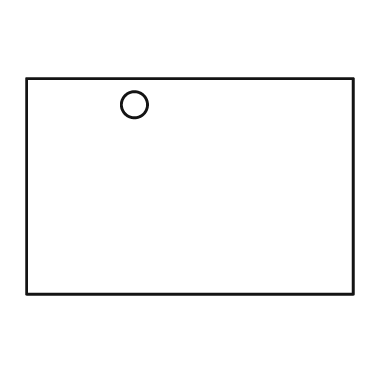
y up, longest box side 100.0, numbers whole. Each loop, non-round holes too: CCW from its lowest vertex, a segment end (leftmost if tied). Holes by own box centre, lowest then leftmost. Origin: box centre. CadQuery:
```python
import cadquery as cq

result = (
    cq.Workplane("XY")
    .moveTo(-50.0, -33.0)
    .lineTo(50.0, -33.0)
    .lineTo(50.0, 33.0)
    .lineTo(-50.0, 33.0)
    .close()
    .moveTo(-17.0, 25.0)
    .circle(4.0)
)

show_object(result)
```